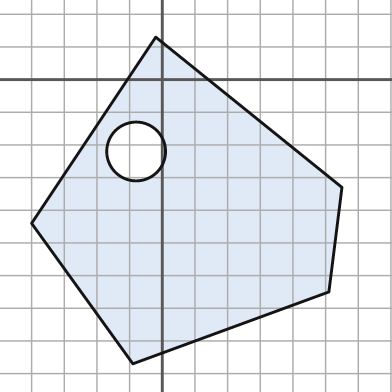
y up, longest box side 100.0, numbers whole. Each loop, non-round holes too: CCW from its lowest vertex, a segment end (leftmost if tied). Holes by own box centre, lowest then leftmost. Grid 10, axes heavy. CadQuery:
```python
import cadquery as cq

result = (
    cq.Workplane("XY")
    .moveTo(-9.0, -87.0)
    .lineTo(51.0, -65.0)
    .lineTo(55.0, -33.0)
    .lineTo(-2.0, 13.0)
    .lineTo(-40.0, -44.0)
    .close()
    .moveTo(-8.0, -22.0)
    .circle(9.0)
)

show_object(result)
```